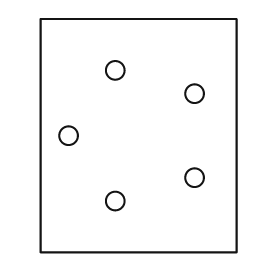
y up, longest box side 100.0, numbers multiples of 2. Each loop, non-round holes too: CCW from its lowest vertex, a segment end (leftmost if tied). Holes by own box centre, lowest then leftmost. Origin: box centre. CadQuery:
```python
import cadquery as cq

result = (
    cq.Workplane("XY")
    .moveTo(-42.0, -50.0)
    .lineTo(42.0, -50.0)
    .lineTo(42.0, 50.0)
    .lineTo(-42.0, 50.0)
    .close()
    .moveTo(-10.0, -28.0)
    .circle(4.0)
    .moveTo(24.0, -18.0)
    .circle(4.0)
    .moveTo(-30.0, 0.0)
    .circle(4.0)
    .moveTo(24.0, 18.0)
    .circle(4.0)
    .moveTo(-10.0, 28.0)
    .circle(4.0)
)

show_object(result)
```